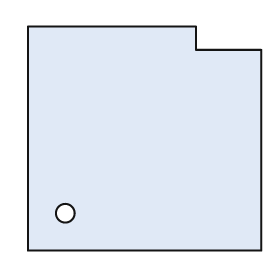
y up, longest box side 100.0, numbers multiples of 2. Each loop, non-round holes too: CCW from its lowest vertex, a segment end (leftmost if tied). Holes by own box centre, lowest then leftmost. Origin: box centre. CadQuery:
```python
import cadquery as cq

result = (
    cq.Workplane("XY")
    .moveTo(-50.0, -48.0)
    .lineTo(50.0, -48.0)
    .lineTo(50.0, 38.0)
    .lineTo(22.0, 38.0)
    .lineTo(22.0, 48.0)
    .lineTo(-50.0, 48.0)
    .close()
    .moveTo(-34.0, -32.0)
    .circle(4.0)
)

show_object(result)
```